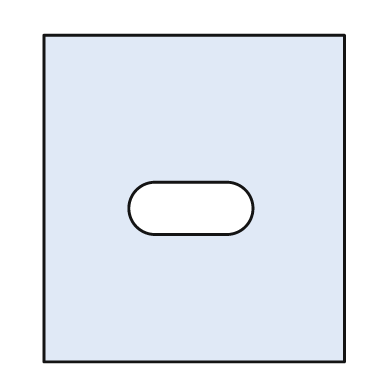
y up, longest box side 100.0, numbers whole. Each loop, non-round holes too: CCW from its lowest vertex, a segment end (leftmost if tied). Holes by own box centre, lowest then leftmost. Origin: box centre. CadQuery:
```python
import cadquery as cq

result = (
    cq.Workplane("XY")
    .moveTo(-46.0, -50.0)
    .lineTo(46.0, -50.0)
    .lineTo(46.0, 50.0)
    .lineTo(-46.0, 50.0)
    .close()
    .moveTo(-12.0, -11.0)
    .lineTo(10.0, -11.0)
    .threePointArc((18.0, -3.0), (10.0, 5.0))
    .lineTo(-12.0, 5.0)
    .threePointArc((-20.0, -3.0), (-12.0, -11.0))
    .close()
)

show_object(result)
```